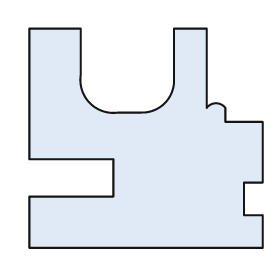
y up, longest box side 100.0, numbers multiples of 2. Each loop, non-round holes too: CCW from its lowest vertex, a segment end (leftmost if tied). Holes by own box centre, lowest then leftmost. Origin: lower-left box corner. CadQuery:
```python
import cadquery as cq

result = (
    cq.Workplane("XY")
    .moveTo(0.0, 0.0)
    .lineTo(100.0, 0.0)
    .lineTo(100.0, 14.0)
    .lineTo(92.0, 14.0)
    .lineTo(92.0, 28.0)
    .lineTo(100.0, 28.0)
    .lineTo(100.0, 54.0)
    .lineTo(84.0, 54.0)
    .lineTo(84.0, 60.0)
    .threePointArc((80.0, 62.0), (76.0, 60.0))
    .lineTo(76.0, 94.0)
    .lineTo(62.0, 94.0)
    .lineTo(62.0, 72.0)
    .threePointArc((58.0, 62.0), (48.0, 58.0))
    .lineTo(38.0, 58.0)
    .threePointArc((26.0, 62.0), (22.0, 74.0))
    .lineTo(22.0, 94.0)
    .lineTo(0.0, 94.0)
    .lineTo(0.0, 38.0)
    .lineTo(36.0, 38.0)
    .lineTo(36.0, 22.0)
    .lineTo(0.0, 22.0)
    .close()
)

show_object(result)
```